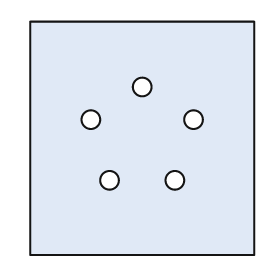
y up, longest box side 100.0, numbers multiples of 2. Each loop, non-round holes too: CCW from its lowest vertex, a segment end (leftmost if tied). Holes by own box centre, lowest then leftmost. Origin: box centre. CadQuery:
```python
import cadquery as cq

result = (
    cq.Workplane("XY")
    .moveTo(-48.0, -50.0)
    .lineTo(48.0, -50.0)
    .lineTo(48.0, 50.0)
    .lineTo(-48.0, 50.0)
    .close()
    .moveTo(-14.0, -18.0)
    .circle(4.0)
    .moveTo(14.0, -18.0)
    .circle(4.0)
    .moveTo(-22.0, 8.0)
    .circle(4.0)
    .moveTo(22.0, 8.0)
    .circle(4.0)
    .moveTo(0.0, 22.0)
    .circle(4.0)
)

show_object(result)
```